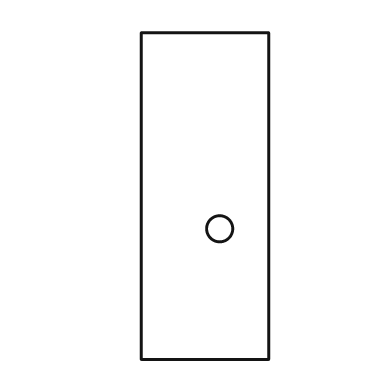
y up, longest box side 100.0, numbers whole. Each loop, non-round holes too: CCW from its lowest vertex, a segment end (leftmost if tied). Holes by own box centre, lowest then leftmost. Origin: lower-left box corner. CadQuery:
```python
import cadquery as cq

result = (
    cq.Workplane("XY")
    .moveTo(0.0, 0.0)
    .lineTo(39.0, 0.0)
    .lineTo(39.0, 100.0)
    .lineTo(0.0, 100.0)
    .close()
    .moveTo(24.0, 40.0)
    .circle(4.0)
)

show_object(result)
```